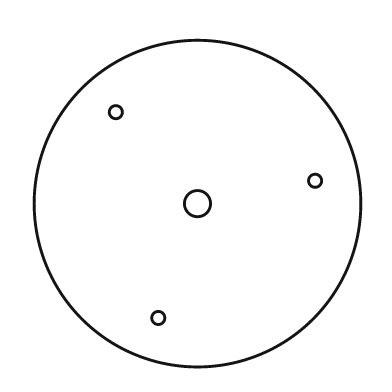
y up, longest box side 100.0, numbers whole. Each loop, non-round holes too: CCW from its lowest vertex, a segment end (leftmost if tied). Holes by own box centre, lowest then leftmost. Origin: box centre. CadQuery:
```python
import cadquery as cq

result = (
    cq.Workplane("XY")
    .moveTo(0.0, 0.0)
    .circle(50.0)
    .moveTo(-12.0, -35.0)
    .circle(2.0)
    .moveTo(0.0, 0.0)
    .circle(4.0)
    .moveTo(36.0, 7.0)
    .circle(2.0)
    .moveTo(-25.0, 28.0)
    .circle(2.0)
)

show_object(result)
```